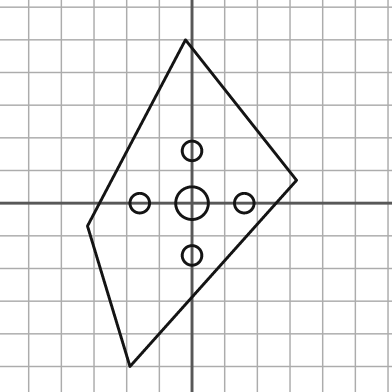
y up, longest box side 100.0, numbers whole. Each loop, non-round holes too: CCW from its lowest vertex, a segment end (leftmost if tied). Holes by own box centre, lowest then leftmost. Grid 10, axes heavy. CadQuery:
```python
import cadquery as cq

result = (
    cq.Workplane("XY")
    .moveTo(-19.0, -50.0)
    .lineTo(32.0, 7.0)
    .lineTo(-2.0, 50.0)
    .lineTo(-32.0, -7.0)
    .close()
    .moveTo(0.0, -16.0)
    .circle(3.0)
    .moveTo(-16.0, 0.0)
    .circle(3.0)
    .moveTo(0.0, 0.0)
    .circle(5.0)
    .moveTo(16.0, 0.0)
    .circle(3.0)
    .moveTo(0.0, 16.0)
    .circle(3.0)
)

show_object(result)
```